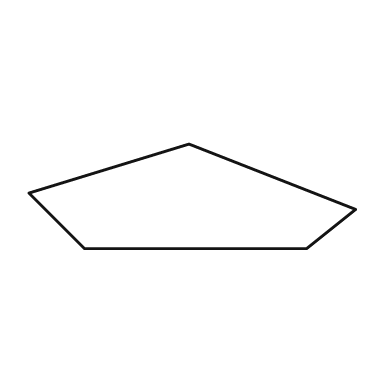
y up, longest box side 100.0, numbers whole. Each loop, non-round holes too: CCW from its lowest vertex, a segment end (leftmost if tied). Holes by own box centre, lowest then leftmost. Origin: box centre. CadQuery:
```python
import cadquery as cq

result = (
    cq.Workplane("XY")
    .moveTo(-33.0, -16.0)
    .lineTo(35.0, -16.0)
    .lineTo(50.0, -4.0)
    .lineTo(-1.0, 16.0)
    .lineTo(-50.0, 1.0)
    .close()
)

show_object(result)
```